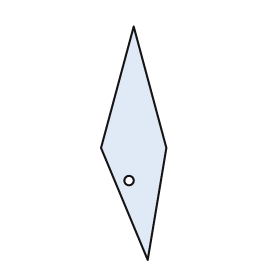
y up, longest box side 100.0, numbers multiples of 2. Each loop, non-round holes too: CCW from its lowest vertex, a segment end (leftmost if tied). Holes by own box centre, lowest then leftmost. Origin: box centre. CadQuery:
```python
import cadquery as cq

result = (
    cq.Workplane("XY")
    .moveTo(6.0, -50.0)
    .lineTo(14.0, -2.0)
    .lineTo(0.0, 50.0)
    .lineTo(-14.0, -2.0)
    .close()
    .moveTo(-2.0, -16.0)
    .circle(2.0)
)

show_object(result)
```